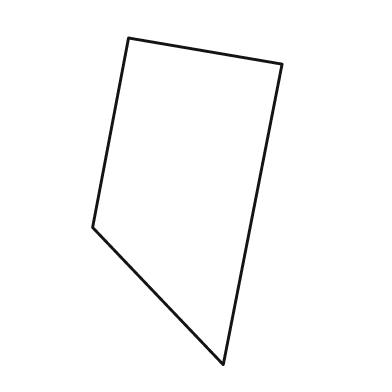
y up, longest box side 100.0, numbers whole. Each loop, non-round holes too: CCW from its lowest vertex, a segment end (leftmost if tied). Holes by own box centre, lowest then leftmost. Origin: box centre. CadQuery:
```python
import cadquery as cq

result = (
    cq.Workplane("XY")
    .moveTo(11.0, -50.0)
    .lineTo(29.0, 42.0)
    .lineTo(-18.0, 50.0)
    .lineTo(-29.0, -8.0)
    .close()
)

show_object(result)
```